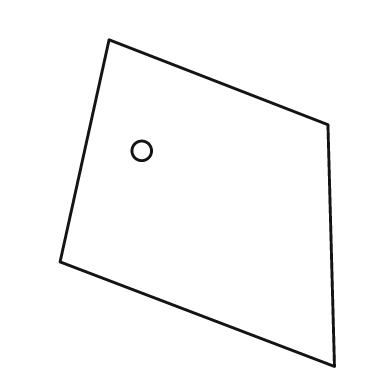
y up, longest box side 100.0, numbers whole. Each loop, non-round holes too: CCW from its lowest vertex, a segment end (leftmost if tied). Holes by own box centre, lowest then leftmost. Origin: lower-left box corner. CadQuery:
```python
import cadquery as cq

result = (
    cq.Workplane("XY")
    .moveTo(84.0, 0.0)
    .lineTo(82.0, 74.0)
    .lineTo(15.0, 100.0)
    .lineTo(0.0, 32.0)
    .close()
    .moveTo(25.0, 66.0)
    .circle(3.0)
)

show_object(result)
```